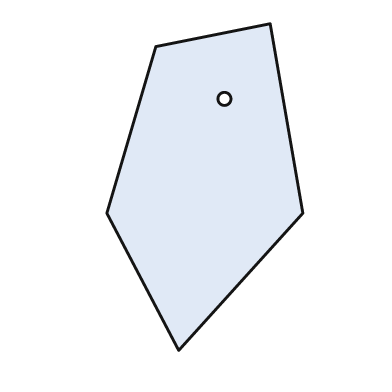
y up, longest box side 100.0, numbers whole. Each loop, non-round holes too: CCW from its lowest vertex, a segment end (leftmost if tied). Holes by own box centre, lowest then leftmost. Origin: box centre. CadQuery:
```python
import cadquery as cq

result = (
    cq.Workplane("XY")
    .moveTo(-8.0, -50.0)
    .lineTo(30.0, -8.0)
    .lineTo(20.0, 50.0)
    .lineTo(-15.0, 43.0)
    .lineTo(-30.0, -8.0)
    .close()
    .moveTo(6.0, 27.0)
    .circle(2.0)
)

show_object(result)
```